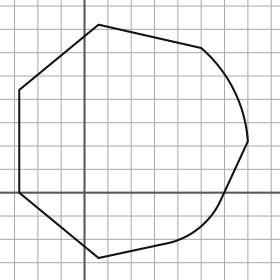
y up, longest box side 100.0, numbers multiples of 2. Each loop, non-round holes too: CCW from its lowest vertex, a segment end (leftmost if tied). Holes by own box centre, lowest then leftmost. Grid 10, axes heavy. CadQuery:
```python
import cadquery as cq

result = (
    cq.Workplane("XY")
    .moveTo(6.0, -28.0)
    .lineTo(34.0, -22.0)
    .threePointArc((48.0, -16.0), (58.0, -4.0))
    .lineTo(70.0, 22.0)
    .threePointArc((64.0, 44.0), (50.0, 62.0))
    .lineTo(6.0, 72.0)
    .lineTo(-28.0, 44.0)
    .lineTo(-28.0, 0.0)
    .close()
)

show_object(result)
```